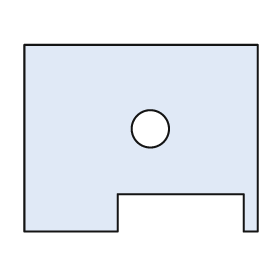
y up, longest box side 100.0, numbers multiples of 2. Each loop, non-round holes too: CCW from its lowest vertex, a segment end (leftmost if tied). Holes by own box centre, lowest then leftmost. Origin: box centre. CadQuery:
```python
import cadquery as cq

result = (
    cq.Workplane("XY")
    .moveTo(-50.0, -40.0)
    .lineTo(-10.0, -40.0)
    .lineTo(-10.0, -24.0)
    .lineTo(44.0, -24.0)
    .lineTo(44.0, -40.0)
    .lineTo(50.0, -40.0)
    .lineTo(50.0, 40.0)
    .lineTo(-50.0, 40.0)
    .close()
    .moveTo(4.0, 4.0)
    .circle(8.0)
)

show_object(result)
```